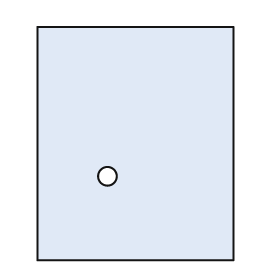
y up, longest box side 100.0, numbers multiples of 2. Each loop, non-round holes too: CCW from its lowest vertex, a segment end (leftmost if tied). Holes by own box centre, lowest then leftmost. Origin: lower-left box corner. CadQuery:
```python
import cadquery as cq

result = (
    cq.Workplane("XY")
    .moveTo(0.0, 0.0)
    .lineTo(84.0, 0.0)
    .lineTo(84.0, 100.0)
    .lineTo(0.0, 100.0)
    .close()
    .moveTo(30.0, 36.0)
    .circle(4.0)
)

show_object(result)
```